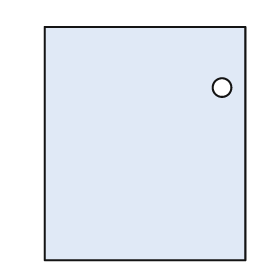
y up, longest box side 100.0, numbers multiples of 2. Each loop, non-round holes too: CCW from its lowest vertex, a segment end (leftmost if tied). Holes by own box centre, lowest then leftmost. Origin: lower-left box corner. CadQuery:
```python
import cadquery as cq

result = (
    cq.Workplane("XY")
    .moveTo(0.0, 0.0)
    .lineTo(86.0, 0.0)
    .lineTo(86.0, 100.0)
    .lineTo(0.0, 100.0)
    .close()
    .moveTo(76.0, 74.0)
    .circle(4.0)
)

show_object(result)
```